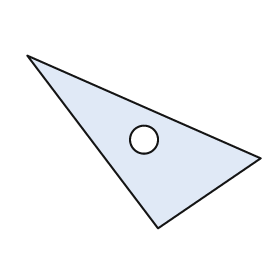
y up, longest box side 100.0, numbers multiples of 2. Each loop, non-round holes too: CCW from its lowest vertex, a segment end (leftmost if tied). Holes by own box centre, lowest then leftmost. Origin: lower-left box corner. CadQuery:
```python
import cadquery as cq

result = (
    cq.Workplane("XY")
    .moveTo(56.0, 0.0)
    .lineTo(100.0, 30.0)
    .lineTo(0.0, 74.0)
    .close()
    .moveTo(50.0, 38.0)
    .circle(6.0)
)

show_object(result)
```